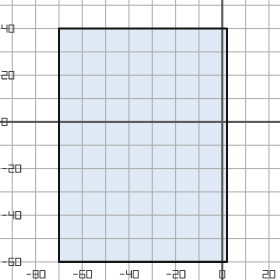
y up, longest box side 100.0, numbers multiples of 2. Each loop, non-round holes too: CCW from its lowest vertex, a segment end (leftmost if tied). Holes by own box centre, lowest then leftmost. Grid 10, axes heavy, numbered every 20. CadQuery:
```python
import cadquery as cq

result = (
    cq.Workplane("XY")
    .moveTo(-70.0, -60.0)
    .lineTo(2.0, -60.0)
    .lineTo(2.0, 40.0)
    .lineTo(-70.0, 40.0)
    .close()
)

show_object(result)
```